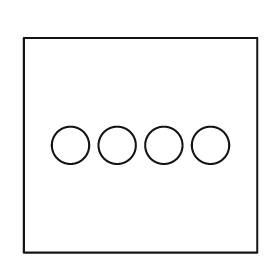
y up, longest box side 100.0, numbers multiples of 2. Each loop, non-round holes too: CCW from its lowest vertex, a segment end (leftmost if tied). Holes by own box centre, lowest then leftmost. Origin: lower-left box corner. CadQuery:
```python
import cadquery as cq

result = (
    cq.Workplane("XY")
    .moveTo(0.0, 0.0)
    .lineTo(100.0, 0.0)
    .lineTo(100.0, 92.0)
    .lineTo(0.0, 92.0)
    .close()
    .moveTo(20.0, 46.0)
    .circle(8.0)
    .moveTo(40.0, 46.0)
    .circle(8.0)
    .moveTo(60.0, 46.0)
    .circle(8.0)
    .moveTo(80.0, 46.0)
    .circle(8.0)
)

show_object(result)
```